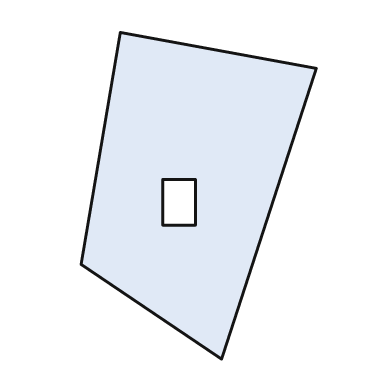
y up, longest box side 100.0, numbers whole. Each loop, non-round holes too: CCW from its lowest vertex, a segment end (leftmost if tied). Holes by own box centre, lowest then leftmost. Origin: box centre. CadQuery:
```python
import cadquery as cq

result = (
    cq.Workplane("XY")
    .moveTo(7.0, -50.0)
    .lineTo(36.0, 39.0)
    .lineTo(-24.0, 50.0)
    .lineTo(-36.0, -21.0)
    .close()
    .moveTo(-11.0, -9.0)
    .lineTo(-1.0, -9.0)
    .lineTo(-1.0, 5.0)
    .lineTo(-11.0, 5.0)
    .close()
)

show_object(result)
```